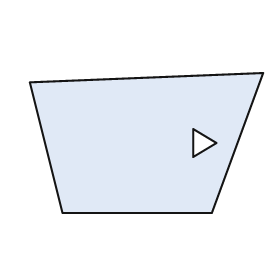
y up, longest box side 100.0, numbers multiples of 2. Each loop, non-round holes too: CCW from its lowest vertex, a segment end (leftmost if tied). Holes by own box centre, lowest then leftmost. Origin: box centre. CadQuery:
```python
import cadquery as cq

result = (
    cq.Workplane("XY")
    .moveTo(-36.0, -30.0)
    .lineTo(28.0, -30.0)
    .lineTo(50.0, 30.0)
    .lineTo(-50.0, 26.0)
    .close()
    .moveTo(20.0, -6.0)
    .lineTo(30.0, 0.0)
    .lineTo(20.0, 6.0)
    .close()
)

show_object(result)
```